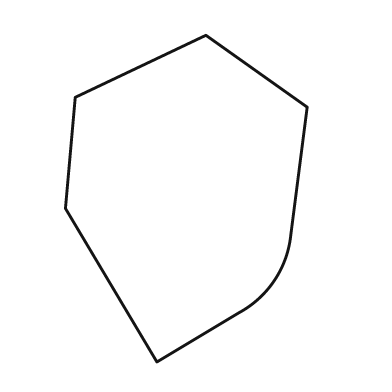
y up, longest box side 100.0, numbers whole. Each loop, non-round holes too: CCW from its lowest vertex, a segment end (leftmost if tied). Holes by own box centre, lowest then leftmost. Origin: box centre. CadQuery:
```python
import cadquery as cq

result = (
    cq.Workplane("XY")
    .moveTo(-9.0, -50.0)
    .lineTo(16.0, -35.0)
    .threePointArc((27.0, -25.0), (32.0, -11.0))
    .lineTo(37.0, 28.0)
    .lineTo(6.0, 50.0)
    .lineTo(-34.0, 31.0)
    .lineTo(-37.0, -3.0)
    .close()
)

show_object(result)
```